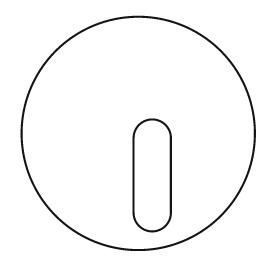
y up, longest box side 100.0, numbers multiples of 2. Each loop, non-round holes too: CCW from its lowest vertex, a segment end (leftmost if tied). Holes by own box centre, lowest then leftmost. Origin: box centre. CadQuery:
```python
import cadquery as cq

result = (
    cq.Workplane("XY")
    .moveTo(0.0, 0.0)
    .circle(50.0)
    .moveTo(-2.0, -34.0)
    .threePointArc((6.0, -42.0), (14.0, -34.0))
    .lineTo(14.0, -2.0)
    .threePointArc((6.0, 6.0), (-2.0, -2.0))
    .close()
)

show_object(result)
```